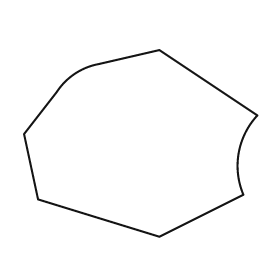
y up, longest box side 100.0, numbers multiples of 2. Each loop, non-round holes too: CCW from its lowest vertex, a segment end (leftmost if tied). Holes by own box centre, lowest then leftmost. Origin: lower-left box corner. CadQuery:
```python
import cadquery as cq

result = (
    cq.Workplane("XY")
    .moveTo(58.0, 0.0)
    .lineTo(94.0, 18.0)
    .threePointArc((92.0, 36.0), (100.0, 52.0))
    .lineTo(58.0, 80.0)
    .lineTo(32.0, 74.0)
    .threePointArc((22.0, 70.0), (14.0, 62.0))
    .lineTo(0.0, 44.0)
    .lineTo(6.0, 16.0)
    .close()
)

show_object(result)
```